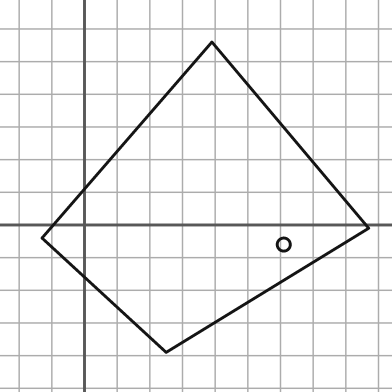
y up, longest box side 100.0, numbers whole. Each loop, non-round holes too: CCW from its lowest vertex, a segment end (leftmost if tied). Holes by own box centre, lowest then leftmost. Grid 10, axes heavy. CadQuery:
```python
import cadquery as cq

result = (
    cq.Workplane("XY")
    .moveTo(25.0, -39.0)
    .lineTo(87.0, -1.0)
    .lineTo(39.0, 56.0)
    .lineTo(-13.0, -4.0)
    .close()
    .moveTo(61.0, -6.0)
    .circle(2.0)
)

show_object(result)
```